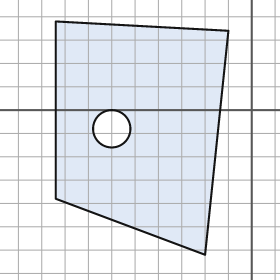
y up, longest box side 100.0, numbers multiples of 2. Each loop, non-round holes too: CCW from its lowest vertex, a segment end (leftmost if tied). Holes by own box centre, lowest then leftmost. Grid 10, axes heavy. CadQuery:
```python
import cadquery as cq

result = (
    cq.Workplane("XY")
    .moveTo(-20.0, -62.0)
    .lineTo(-10.0, 34.0)
    .lineTo(-84.0, 38.0)
    .lineTo(-84.0, -38.0)
    .close()
    .moveTo(-60.0, -8.0)
    .circle(8.0)
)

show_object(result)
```